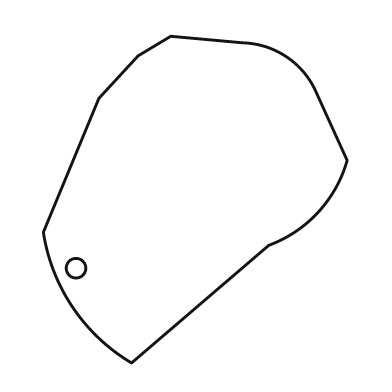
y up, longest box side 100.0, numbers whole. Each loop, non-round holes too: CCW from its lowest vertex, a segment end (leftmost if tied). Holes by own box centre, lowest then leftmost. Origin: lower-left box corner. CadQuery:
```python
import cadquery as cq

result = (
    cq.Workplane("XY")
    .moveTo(27.0, 0.0)
    .lineTo(69.0, 36.0)
    .threePointArc((84.0, 46.0), (93.0, 62.0))
    .lineTo(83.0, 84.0)
    .threePointArc((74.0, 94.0), (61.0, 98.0))
    .lineTo(39.0, 100.0)
    .lineTo(29.0, 94.0)
    .lineTo(17.0, 81.0)
    .lineTo(0.0, 40.0)
    .threePointArc((9.0, 17.0), (27.0, 0.0))
    .close()
    .moveTo(10.0, 29.0)
    .circle(3.0)
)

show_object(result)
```